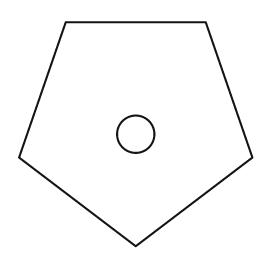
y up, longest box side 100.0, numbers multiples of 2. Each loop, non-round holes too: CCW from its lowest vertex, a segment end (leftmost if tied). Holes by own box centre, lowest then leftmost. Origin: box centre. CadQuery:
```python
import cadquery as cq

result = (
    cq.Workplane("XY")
    .moveTo(0.0, -48.0)
    .lineTo(50.0, -10.0)
    .lineTo(30.0, 48.0)
    .lineTo(-30.0, 48.0)
    .lineTo(-50.0, -10.0)
    .close()
    .moveTo(0.0, 0.0)
    .circle(8.0)
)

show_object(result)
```